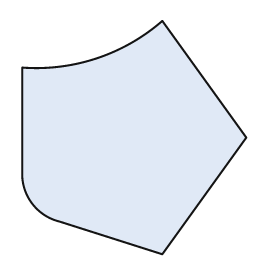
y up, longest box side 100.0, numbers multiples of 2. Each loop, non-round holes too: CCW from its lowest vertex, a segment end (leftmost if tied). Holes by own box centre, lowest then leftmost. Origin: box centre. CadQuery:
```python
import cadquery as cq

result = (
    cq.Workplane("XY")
    .moveTo(12.0, -50.0)
    .lineTo(48.0, 0.0)
    .lineTo(12.0, 50.0)
    .threePointArc((-16.0, 34.0), (-48.0, 30.0))
    .lineTo(-48.0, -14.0)
    .threePointArc((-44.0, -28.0), (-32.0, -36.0))
    .close()
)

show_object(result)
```